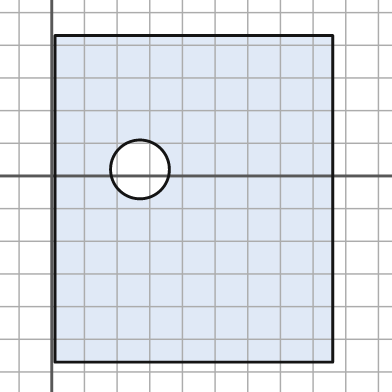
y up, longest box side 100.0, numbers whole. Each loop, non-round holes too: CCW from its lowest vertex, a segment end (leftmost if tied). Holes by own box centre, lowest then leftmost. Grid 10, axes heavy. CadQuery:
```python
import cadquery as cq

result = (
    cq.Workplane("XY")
    .moveTo(1.0, -57.0)
    .lineTo(86.0, -57.0)
    .lineTo(86.0, 43.0)
    .lineTo(1.0, 43.0)
    .close()
    .moveTo(27.0, 2.0)
    .circle(9.0)
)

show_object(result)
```